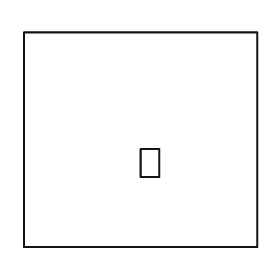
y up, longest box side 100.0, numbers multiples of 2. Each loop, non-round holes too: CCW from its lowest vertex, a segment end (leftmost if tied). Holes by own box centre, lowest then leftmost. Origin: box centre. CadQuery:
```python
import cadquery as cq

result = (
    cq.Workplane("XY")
    .moveTo(-50.0, -46.0)
    .lineTo(50.0, -46.0)
    .lineTo(50.0, 46.0)
    .lineTo(-50.0, 46.0)
    .close()
    .moveTo(0.0, -16.0)
    .lineTo(8.0, -16.0)
    .lineTo(8.0, -4.0)
    .lineTo(0.0, -4.0)
    .close()
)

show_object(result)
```